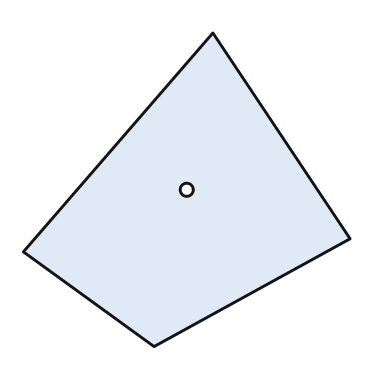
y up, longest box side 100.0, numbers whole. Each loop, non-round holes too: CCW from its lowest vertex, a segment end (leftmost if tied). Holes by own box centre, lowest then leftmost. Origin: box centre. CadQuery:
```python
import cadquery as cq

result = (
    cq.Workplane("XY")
    .moveTo(-10.0, -48.0)
    .lineTo(50.0, -15.0)
    .lineTo(8.0, 48.0)
    .lineTo(-50.0, -19.0)
    .close()
    .moveTo(0.0, 0.0)
    .circle(2.0)
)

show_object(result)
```